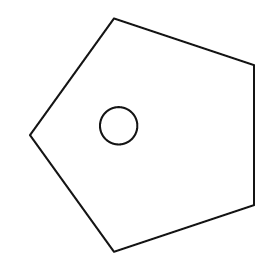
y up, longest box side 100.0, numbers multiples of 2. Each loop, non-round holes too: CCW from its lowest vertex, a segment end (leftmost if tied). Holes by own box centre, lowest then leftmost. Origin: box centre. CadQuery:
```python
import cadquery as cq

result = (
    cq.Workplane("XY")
    .moveTo(-12.0, -50.0)
    .lineTo(48.0, -30.0)
    .lineTo(48.0, 30.0)
    .lineTo(-12.0, 50.0)
    .lineTo(-48.0, 0.0)
    .close()
    .moveTo(-10.0, 4.0)
    .circle(8.0)
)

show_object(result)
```